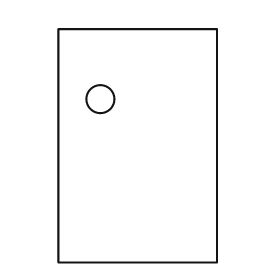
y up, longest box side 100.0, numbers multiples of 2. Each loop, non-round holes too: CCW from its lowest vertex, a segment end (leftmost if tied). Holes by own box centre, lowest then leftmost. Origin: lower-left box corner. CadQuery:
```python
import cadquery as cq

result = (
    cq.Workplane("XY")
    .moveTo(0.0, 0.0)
    .lineTo(68.0, 0.0)
    .lineTo(68.0, 100.0)
    .lineTo(0.0, 100.0)
    .close()
    .moveTo(18.0, 70.0)
    .circle(6.0)
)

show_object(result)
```